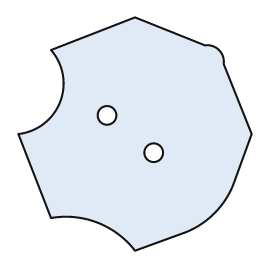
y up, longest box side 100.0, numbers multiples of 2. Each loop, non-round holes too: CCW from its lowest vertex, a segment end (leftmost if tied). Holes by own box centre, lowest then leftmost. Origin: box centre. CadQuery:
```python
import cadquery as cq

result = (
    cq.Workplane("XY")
    .moveTo(0.0, -50.0)
    .lineTo(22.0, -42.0)
    .threePointArc((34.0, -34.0), (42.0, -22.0))
    .lineTo(50.0, 0.0)
    .lineTo(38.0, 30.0)
    .threePointArc((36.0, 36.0), (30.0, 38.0))
    .lineTo(0.0, 50.0)
    .lineTo(-36.0, 36.0)
    .threePointArc((-32.0, 14.0), (-50.0, 0.0))
    .lineTo(-36.0, -36.0)
    .threePointArc((-16.0, -38.0), (0.0, -50.0))
    .close()
    .moveTo(8.0, -8.0)
    .circle(4.0)
    .moveTo(-12.0, 8.0)
    .circle(4.0)
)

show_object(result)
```